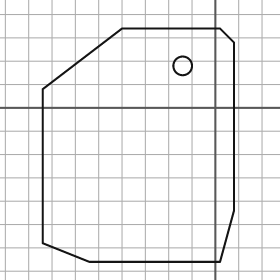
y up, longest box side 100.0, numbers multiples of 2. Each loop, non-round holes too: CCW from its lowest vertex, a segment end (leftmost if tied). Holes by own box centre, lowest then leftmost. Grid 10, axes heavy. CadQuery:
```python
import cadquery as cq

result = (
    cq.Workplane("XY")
    .moveTo(-54.0, -66.0)
    .lineTo(2.0, -66.0)
    .lineTo(8.0, -44.0)
    .lineTo(8.0, 28.0)
    .lineTo(2.0, 34.0)
    .lineTo(-40.0, 34.0)
    .lineTo(-74.0, 8.0)
    .lineTo(-74.0, -58.0)
    .close()
    .moveTo(-14.0, 18.0)
    .circle(4.0)
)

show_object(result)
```